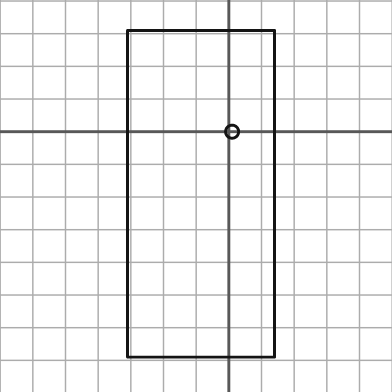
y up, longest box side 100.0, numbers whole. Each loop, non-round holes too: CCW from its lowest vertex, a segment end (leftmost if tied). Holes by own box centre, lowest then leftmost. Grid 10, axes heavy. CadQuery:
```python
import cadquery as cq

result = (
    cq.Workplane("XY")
    .moveTo(-31.0, -69.0)
    .lineTo(14.0, -69.0)
    .lineTo(14.0, 31.0)
    .lineTo(-31.0, 31.0)
    .close()
    .moveTo(1.0, 0.0)
    .circle(2.0)
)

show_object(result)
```